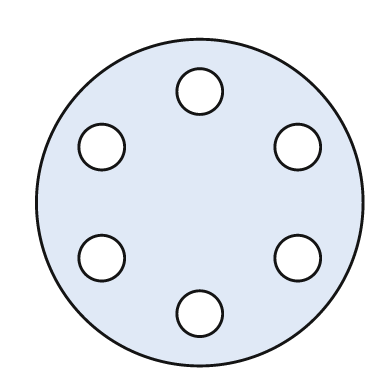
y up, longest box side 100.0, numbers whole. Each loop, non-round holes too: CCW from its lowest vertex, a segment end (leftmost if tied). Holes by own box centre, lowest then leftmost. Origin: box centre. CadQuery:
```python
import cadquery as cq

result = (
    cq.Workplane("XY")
    .moveTo(0.0, 0.0)
    .circle(50.0)
    .moveTo(0.0, -34.0)
    .circle(7.0)
    .moveTo(-30.0, -17.0)
    .circle(7.0)
    .moveTo(30.0, -17.0)
    .circle(7.0)
    .moveTo(-30.0, 17.0)
    .circle(7.0)
    .moveTo(30.0, 17.0)
    .circle(7.0)
    .moveTo(0.0, 34.0)
    .circle(7.0)
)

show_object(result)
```